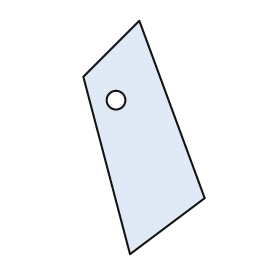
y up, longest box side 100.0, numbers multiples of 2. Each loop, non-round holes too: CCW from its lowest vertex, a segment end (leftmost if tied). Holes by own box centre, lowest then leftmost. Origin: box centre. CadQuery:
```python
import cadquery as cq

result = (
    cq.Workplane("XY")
    .moveTo(-6.0, -50.0)
    .lineTo(26.0, -26.0)
    .lineTo(-2.0, 50.0)
    .lineTo(-26.0, 26.0)
    .close()
    .moveTo(-12.0, 16.0)
    .circle(4.0)
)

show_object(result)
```